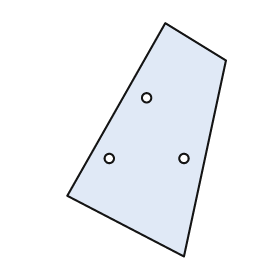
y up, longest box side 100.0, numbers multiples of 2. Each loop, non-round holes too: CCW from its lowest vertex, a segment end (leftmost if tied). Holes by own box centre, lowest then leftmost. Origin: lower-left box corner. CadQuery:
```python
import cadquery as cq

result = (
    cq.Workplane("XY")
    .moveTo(50.0, 0.0)
    .lineTo(68.0, 84.0)
    .lineTo(42.0, 100.0)
    .lineTo(0.0, 26.0)
    .close()
    .moveTo(18.0, 42.0)
    .circle(2.0)
    .moveTo(50.0, 42.0)
    .circle(2.0)
    .moveTo(34.0, 68.0)
    .circle(2.0)
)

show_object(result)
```